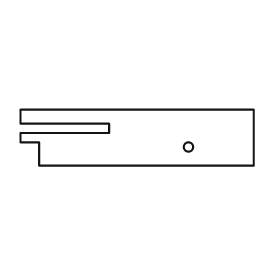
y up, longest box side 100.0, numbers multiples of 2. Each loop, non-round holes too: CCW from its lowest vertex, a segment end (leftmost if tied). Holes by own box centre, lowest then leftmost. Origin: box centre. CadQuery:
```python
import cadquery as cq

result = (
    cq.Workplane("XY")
    .moveTo(-42.0, -12.0)
    .lineTo(50.0, -12.0)
    .lineTo(50.0, 12.0)
    .lineTo(-50.0, 12.0)
    .lineTo(-50.0, 6.0)
    .lineTo(-12.0, 6.0)
    .lineTo(-12.0, 2.0)
    .lineTo(-50.0, 2.0)
    .lineTo(-50.0, -2.0)
    .lineTo(-42.0, -2.0)
    .close()
    .moveTo(22.0, -4.0)
    .circle(2.0)
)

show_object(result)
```